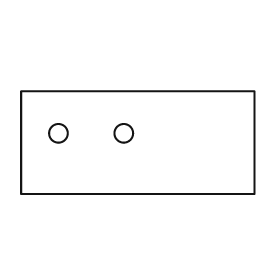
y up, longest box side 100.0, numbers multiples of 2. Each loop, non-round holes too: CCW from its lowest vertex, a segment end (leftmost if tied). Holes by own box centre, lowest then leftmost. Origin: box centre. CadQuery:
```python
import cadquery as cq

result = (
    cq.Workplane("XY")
    .moveTo(-50.0, -22.0)
    .lineTo(50.0, -22.0)
    .lineTo(50.0, 22.0)
    .lineTo(-50.0, 22.0)
    .close()
    .moveTo(-34.0, 4.0)
    .circle(4.0)
    .moveTo(-6.0, 4.0)
    .circle(4.0)
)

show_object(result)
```